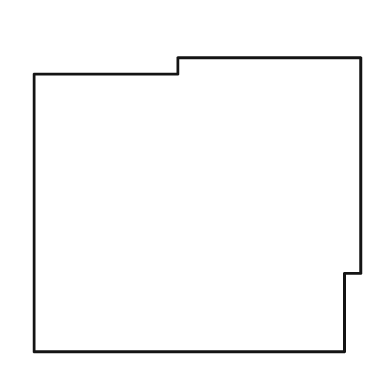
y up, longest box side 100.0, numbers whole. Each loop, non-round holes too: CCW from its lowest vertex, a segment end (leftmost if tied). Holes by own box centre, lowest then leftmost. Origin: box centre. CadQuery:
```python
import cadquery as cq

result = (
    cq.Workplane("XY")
    .moveTo(-50.0, -45.0)
    .lineTo(45.0, -45.0)
    .lineTo(45.0, -21.0)
    .lineTo(50.0, -21.0)
    .lineTo(50.0, 45.0)
    .lineTo(-6.0, 45.0)
    .lineTo(-6.0, 40.0)
    .lineTo(-50.0, 40.0)
    .close()
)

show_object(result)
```